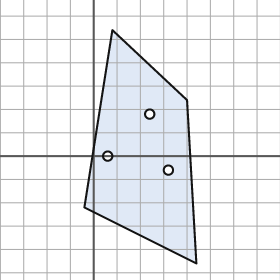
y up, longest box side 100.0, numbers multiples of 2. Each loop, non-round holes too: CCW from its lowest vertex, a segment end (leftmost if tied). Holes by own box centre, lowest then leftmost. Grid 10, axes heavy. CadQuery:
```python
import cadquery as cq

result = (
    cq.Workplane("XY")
    .moveTo(44.0, -46.0)
    .lineTo(40.0, 24.0)
    .lineTo(8.0, 54.0)
    .lineTo(-4.0, -22.0)
    .close()
    .moveTo(32.0, -6.0)
    .circle(2.0)
    .moveTo(6.0, 0.0)
    .circle(2.0)
    .moveTo(24.0, 18.0)
    .circle(2.0)
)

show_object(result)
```